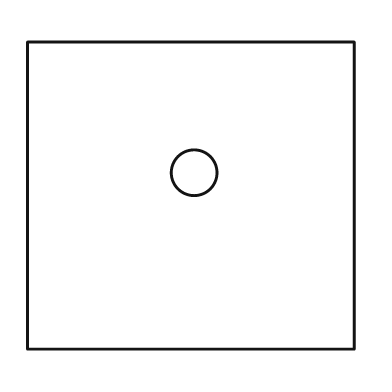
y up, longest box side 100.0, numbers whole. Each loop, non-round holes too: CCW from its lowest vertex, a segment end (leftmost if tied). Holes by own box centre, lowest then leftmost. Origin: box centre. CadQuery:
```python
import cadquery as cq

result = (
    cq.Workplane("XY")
    .moveTo(-50.0, -47.0)
    .lineTo(50.0, -47.0)
    .lineTo(50.0, 47.0)
    .lineTo(-50.0, 47.0)
    .close()
    .moveTo(1.0, 7.0)
    .circle(7.0)
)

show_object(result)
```